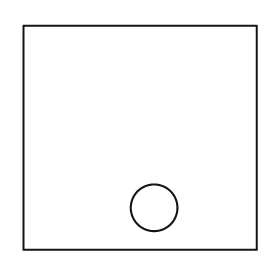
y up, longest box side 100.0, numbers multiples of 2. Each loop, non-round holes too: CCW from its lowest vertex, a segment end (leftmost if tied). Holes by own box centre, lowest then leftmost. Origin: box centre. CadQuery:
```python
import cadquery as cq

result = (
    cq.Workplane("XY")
    .moveTo(-50.0, -48.0)
    .lineTo(50.0, -48.0)
    .lineTo(50.0, 48.0)
    .lineTo(-50.0, 48.0)
    .close()
    .moveTo(6.0, -30.0)
    .circle(10.0)
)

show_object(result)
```